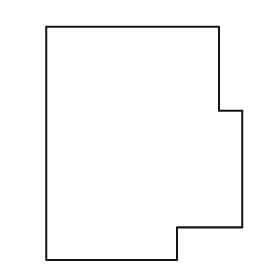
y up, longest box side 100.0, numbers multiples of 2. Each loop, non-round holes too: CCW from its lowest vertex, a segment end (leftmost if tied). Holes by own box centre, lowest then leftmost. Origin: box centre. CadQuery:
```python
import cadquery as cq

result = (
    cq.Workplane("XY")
    .moveTo(-42.0, -50.0)
    .lineTo(14.0, -50.0)
    .lineTo(14.0, -36.0)
    .lineTo(42.0, -36.0)
    .lineTo(42.0, 14.0)
    .lineTo(32.0, 14.0)
    .lineTo(32.0, 50.0)
    .lineTo(-42.0, 50.0)
    .close()
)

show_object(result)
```